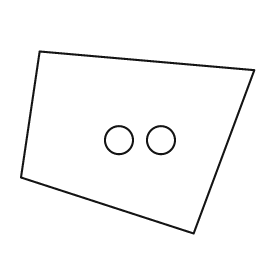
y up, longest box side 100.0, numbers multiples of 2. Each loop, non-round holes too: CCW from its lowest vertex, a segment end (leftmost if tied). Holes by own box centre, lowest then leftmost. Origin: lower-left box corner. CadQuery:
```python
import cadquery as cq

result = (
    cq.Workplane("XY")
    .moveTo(74.0, 0.0)
    .lineTo(100.0, 70.0)
    .lineTo(8.0, 78.0)
    .lineTo(0.0, 24.0)
    .close()
    .moveTo(42.0, 40.0)
    .circle(6.0)
    .moveTo(60.0, 40.0)
    .circle(6.0)
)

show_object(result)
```